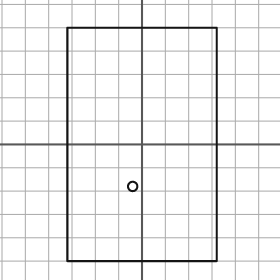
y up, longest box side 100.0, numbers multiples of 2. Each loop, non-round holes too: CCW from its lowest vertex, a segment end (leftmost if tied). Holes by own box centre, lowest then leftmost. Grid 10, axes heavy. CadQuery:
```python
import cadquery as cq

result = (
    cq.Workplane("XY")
    .moveTo(-32.0, -50.0)
    .lineTo(32.0, -50.0)
    .lineTo(32.0, 50.0)
    .lineTo(-32.0, 50.0)
    .close()
    .moveTo(-4.0, -18.0)
    .circle(2.0)
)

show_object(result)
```